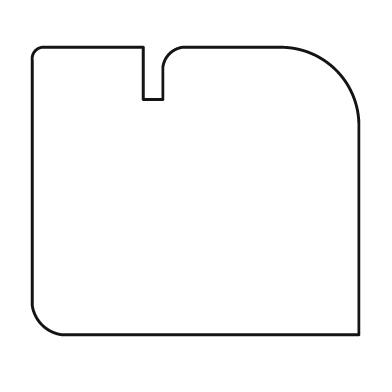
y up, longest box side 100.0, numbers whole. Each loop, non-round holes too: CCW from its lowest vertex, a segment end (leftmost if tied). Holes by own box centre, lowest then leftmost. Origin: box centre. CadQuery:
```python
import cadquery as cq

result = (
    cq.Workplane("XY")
    .moveTo(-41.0, -44.0)
    .lineTo(50.0, -44.0)
    .lineTo(50.0, 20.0)
    .threePointArc((43.0, 37.0), (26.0, 44.0))
    .lineTo(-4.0, 44.0)
    .threePointArc((-8.0, 42.0), (-10.0, 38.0))
    .lineTo(-10.0, 28.0)
    .lineTo(-16.0, 28.0)
    .lineTo(-16.0, 44.0)
    .lineTo(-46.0, 44.0)
    .threePointArc((-49.0, 43.0), (-50.0, 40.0))
    .lineTo(-50.0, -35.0)
    .threePointArc((-47.0, -41.0), (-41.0, -44.0))
    .close()
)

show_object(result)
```